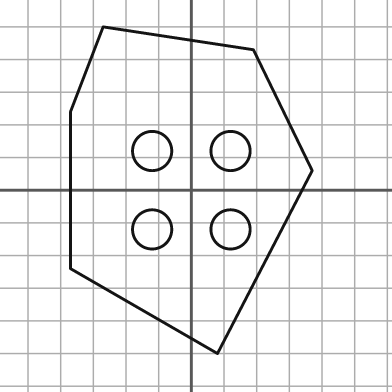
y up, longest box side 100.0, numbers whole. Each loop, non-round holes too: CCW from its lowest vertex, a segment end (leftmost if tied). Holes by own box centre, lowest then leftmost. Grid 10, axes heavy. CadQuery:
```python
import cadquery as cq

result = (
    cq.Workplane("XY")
    .moveTo(8.0, -50.0)
    .lineTo(37.0, 6.0)
    .lineTo(19.0, 43.0)
    .lineTo(-27.0, 50.0)
    .lineTo(-37.0, 24.0)
    .lineTo(-37.0, -24.0)
    .close()
    .moveTo(-12.0, -12.0)
    .circle(6.0)
    .moveTo(12.0, -12.0)
    .circle(6.0)
    .moveTo(-12.0, 12.0)
    .circle(6.0)
    .moveTo(12.0, 12.0)
    .circle(6.0)
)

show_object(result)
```